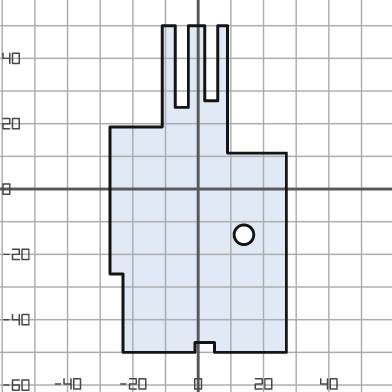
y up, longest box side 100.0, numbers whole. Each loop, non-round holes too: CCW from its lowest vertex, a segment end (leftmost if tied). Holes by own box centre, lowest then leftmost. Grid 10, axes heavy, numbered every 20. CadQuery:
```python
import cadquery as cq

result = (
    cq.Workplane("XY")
    .moveTo(-23.0, -50.0)
    .lineTo(-1.0, -50.0)
    .lineTo(-1.0, -47.0)
    .lineTo(5.0, -47.0)
    .lineTo(5.0, -50.0)
    .lineTo(27.0, -50.0)
    .lineTo(27.0, 11.0)
    .lineTo(9.0, 11.0)
    .lineTo(9.0, 50.0)
    .lineTo(6.0, 50.0)
    .lineTo(6.0, 27.0)
    .lineTo(2.0, 27.0)
    .lineTo(2.0, 50.0)
    .lineTo(-3.0, 50.0)
    .lineTo(-3.0, 25.0)
    .lineTo(-7.0, 25.0)
    .lineTo(-7.0, 50.0)
    .lineTo(-11.0, 50.0)
    .lineTo(-11.0, 19.0)
    .lineTo(-27.0, 19.0)
    .lineTo(-27.0, -26.0)
    .lineTo(-23.0, -26.0)
    .close()
    .moveTo(14.0, -14.0)
    .circle(3.0)
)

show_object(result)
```